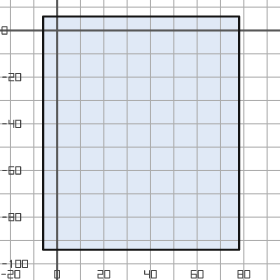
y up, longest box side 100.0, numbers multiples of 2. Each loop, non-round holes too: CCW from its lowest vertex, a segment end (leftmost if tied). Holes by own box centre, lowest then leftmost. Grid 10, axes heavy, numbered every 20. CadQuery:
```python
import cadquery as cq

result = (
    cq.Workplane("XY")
    .moveTo(-6.0, -94.0)
    .lineTo(78.0, -94.0)
    .lineTo(78.0, 6.0)
    .lineTo(-6.0, 6.0)
    .close()
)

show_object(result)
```